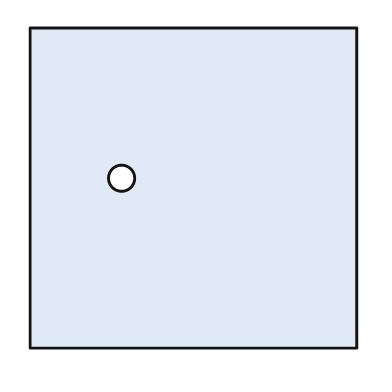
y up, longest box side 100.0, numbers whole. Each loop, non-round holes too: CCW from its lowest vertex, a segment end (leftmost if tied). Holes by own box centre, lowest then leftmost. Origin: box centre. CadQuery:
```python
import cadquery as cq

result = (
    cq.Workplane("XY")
    .moveTo(-50.0, -49.0)
    .lineTo(50.0, -49.0)
    .lineTo(50.0, 49.0)
    .lineTo(-50.0, 49.0)
    .close()
    .moveTo(-22.0, 3.0)
    .circle(4.0)
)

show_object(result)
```